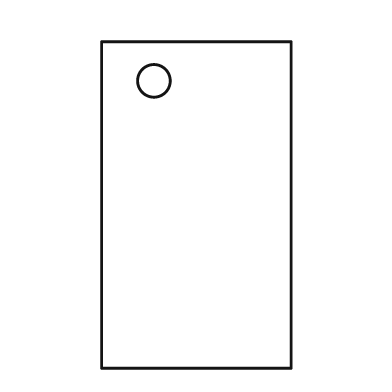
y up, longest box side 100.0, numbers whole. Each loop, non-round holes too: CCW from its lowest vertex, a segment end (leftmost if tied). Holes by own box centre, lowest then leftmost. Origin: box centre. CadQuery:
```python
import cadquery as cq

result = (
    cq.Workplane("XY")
    .moveTo(-29.0, -50.0)
    .lineTo(29.0, -50.0)
    .lineTo(29.0, 50.0)
    .lineTo(-29.0, 50.0)
    .close()
    .moveTo(-13.0, 38.0)
    .circle(5.0)
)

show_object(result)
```